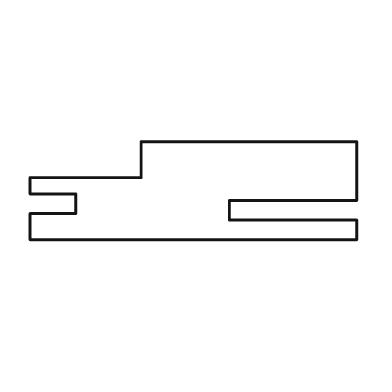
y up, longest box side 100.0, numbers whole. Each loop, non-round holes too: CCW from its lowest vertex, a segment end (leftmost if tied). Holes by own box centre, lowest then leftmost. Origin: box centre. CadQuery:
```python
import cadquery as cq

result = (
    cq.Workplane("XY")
    .moveTo(-50.0, -15.0)
    .lineTo(50.0, -15.0)
    .lineTo(50.0, -9.0)
    .lineTo(11.0, -9.0)
    .lineTo(11.0, -3.0)
    .lineTo(50.0, -3.0)
    .lineTo(50.0, 15.0)
    .lineTo(-16.0, 15.0)
    .lineTo(-16.0, 4.0)
    .lineTo(-50.0, 4.0)
    .lineTo(-50.0, -1.0)
    .lineTo(-36.0, -1.0)
    .lineTo(-36.0, -7.0)
    .lineTo(-50.0, -7.0)
    .close()
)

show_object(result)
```